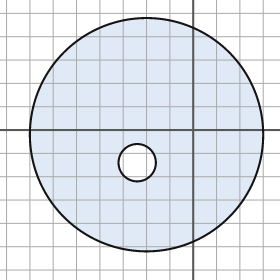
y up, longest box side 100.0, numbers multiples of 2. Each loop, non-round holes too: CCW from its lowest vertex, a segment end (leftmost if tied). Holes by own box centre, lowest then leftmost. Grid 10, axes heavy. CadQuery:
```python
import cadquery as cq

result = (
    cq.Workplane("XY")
    .moveTo(-20.0, -2.0)
    .circle(50.0)
    .moveTo(-24.0, -14.0)
    .circle(8.0)
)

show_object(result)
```